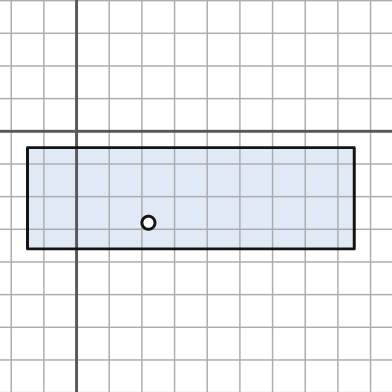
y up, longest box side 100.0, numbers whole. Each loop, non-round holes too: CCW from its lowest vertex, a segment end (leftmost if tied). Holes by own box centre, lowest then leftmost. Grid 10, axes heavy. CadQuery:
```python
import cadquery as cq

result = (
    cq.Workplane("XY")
    .moveTo(-15.0, -36.0)
    .lineTo(85.0, -36.0)
    .lineTo(85.0, -5.0)
    .lineTo(-15.0, -5.0)
    .close()
    .moveTo(22.0, -28.0)
    .circle(2.0)
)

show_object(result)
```